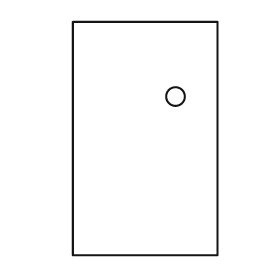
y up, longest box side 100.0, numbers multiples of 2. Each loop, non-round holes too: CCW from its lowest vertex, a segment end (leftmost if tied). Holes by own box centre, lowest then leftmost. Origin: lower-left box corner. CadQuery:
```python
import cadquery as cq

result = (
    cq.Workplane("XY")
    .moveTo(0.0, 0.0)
    .lineTo(62.0, 0.0)
    .lineTo(62.0, 100.0)
    .lineTo(0.0, 100.0)
    .close()
    .moveTo(44.0, 68.0)
    .circle(4.0)
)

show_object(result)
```